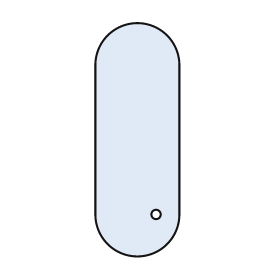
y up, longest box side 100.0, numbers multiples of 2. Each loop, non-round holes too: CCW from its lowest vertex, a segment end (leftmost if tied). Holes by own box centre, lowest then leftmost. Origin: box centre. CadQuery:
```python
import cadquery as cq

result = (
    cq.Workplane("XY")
    .moveTo(-18.0, -32.0)
    .threePointArc((0.0, -50.0), (18.0, -32.0))
    .lineTo(18.0, 32.0)
    .threePointArc((0.0, 50.0), (-18.0, 32.0))
    .close()
    .moveTo(8.0, -32.0)
    .circle(2.0)
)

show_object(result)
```